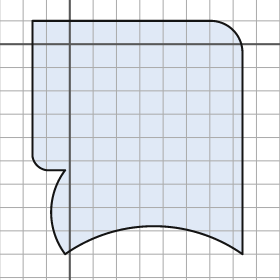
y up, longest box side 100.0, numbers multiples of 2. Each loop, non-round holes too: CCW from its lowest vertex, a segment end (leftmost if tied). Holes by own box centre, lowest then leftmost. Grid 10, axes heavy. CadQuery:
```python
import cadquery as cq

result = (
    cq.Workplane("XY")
    .moveTo(-2.0, -90.0)
    .threePointArc((36.0, -78.0), (74.0, -90.0))
    .lineTo(74.0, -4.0)
    .threePointArc((70.0, 6.0), (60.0, 10.0))
    .lineTo(-16.0, 10.0)
    .lineTo(-16.0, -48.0)
    .threePointArc((-14.0, -52.0), (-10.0, -54.0))
    .lineTo(-2.0, -54.0)
    .threePointArc((-8.0, -72.0), (-2.0, -90.0))
    .close()
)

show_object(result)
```